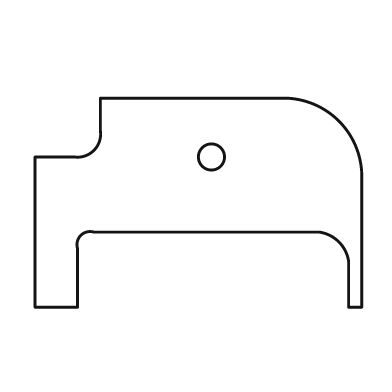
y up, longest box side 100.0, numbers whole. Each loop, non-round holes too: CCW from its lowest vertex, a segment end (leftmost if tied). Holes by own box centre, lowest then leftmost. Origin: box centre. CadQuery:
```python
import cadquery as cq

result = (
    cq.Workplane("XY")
    .moveTo(-50.0, -32.0)
    .lineTo(-37.0, -32.0)
    .lineTo(-37.0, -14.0)
    .threePointArc((-36.0, -10.0), (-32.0, -9.0))
    .lineTo(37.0, -9.0)
    .threePointArc((43.0, -12.0), (46.0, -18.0))
    .lineTo(46.0, -32.0)
    .lineTo(50.0, -32.0)
    .lineTo(50.0, 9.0)
    .threePointArc((43.0, 25.0), (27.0, 32.0))
    .lineTo(-30.0, 32.0)
    .lineTo(-30.0, 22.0)
    .threePointArc((-32.0, 16.0), (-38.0, 14.0))
    .lineTo(-50.0, 14.0)
    .close()
    .moveTo(4.0, 14.0)
    .circle(4.0)
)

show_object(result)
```